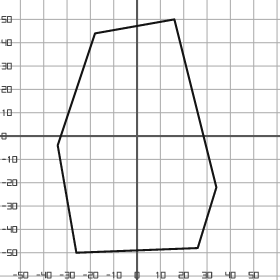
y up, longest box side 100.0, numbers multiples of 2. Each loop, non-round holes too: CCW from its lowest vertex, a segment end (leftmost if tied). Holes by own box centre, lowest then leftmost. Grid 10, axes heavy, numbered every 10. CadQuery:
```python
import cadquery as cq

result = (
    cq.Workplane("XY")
    .moveTo(-26.0, -50.0)
    .lineTo(26.0, -48.0)
    .lineTo(34.0, -22.0)
    .lineTo(16.0, 50.0)
    .lineTo(-18.0, 44.0)
    .lineTo(-34.0, -4.0)
    .close()
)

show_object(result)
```